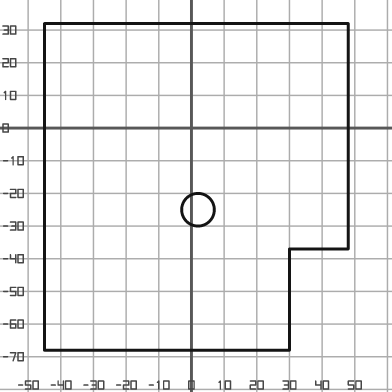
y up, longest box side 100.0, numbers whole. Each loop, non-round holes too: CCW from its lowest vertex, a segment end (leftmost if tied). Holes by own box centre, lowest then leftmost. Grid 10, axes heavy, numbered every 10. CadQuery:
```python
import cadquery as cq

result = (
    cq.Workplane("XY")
    .moveTo(-45.0, -68.0)
    .lineTo(30.0, -68.0)
    .lineTo(30.0, -37.0)
    .lineTo(48.0, -37.0)
    .lineTo(48.0, 32.0)
    .lineTo(-45.0, 32.0)
    .close()
    .moveTo(2.0, -25.0)
    .circle(5.0)
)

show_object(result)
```